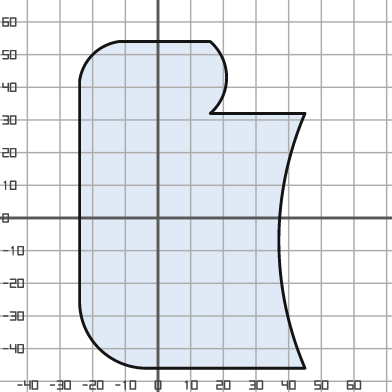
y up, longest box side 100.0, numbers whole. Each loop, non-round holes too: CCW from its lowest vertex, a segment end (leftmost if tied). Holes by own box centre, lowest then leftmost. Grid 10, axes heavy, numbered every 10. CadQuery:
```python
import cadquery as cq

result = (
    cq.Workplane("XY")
    .moveTo(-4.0, -46.0)
    .lineTo(45.0, -46.0)
    .threePointArc((37.0, -7.0), (45.0, 32.0))
    .lineTo(16.0, 32.0)
    .threePointArc((21.0, 43.0), (16.0, 54.0))
    .lineTo(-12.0, 54.0)
    .threePointArc((-20.0, 50.0), (-24.0, 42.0))
    .lineTo(-24.0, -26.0)
    .threePointArc((-18.0, -40.0), (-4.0, -46.0))
    .close()
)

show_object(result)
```